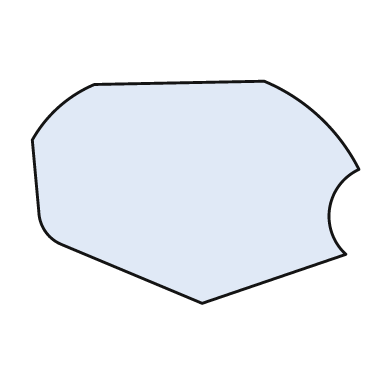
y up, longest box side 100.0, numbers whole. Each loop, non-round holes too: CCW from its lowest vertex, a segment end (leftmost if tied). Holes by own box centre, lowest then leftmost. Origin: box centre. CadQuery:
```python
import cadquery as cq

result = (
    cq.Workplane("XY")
    .moveTo(2.0, -34.0)
    .lineTo(46.0, -19.0)
    .threePointArc((41.0, -5.0), (50.0, 7.0))
    .threePointArc((38.0, 23.0), (21.0, 34.0))
    .lineTo(-31.0, 33.0)
    .threePointArc((-42.0, 26.0), (-50.0, 16.0))
    .lineTo(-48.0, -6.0)
    .threePointArc((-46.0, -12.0), (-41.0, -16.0))
    .close()
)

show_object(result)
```